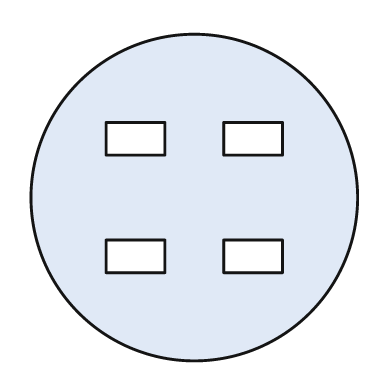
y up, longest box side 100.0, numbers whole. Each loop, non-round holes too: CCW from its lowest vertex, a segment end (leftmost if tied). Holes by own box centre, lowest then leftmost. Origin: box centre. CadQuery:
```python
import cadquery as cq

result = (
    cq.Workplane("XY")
    .moveTo(0.0, 0.0)
    .circle(50.0)
    .moveTo(-27.0, -23.0)
    .lineTo(-9.0, -23.0)
    .lineTo(-9.0, -13.0)
    .lineTo(-27.0, -13.0)
    .close()
    .moveTo(9.0, -23.0)
    .lineTo(27.0, -23.0)
    .lineTo(27.0, -13.0)
    .lineTo(9.0, -13.0)
    .close()
    .moveTo(-27.0, 13.0)
    .lineTo(-9.0, 13.0)
    .lineTo(-9.0, 23.0)
    .lineTo(-27.0, 23.0)
    .close()
    .moveTo(9.0, 13.0)
    .lineTo(27.0, 13.0)
    .lineTo(27.0, 23.0)
    .lineTo(9.0, 23.0)
    .close()
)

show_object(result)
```